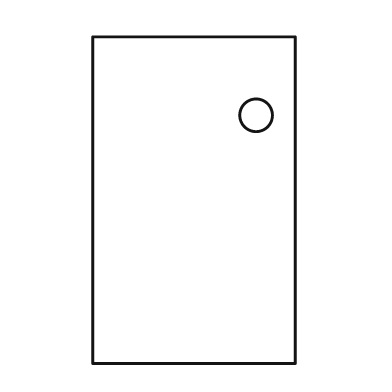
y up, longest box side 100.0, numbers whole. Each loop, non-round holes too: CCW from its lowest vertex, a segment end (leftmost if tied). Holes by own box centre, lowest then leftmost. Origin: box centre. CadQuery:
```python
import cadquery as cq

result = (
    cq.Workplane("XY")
    .moveTo(-31.0, -50.0)
    .lineTo(31.0, -50.0)
    .lineTo(31.0, 50.0)
    .lineTo(-31.0, 50.0)
    .close()
    .moveTo(19.0, 26.0)
    .circle(5.0)
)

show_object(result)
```